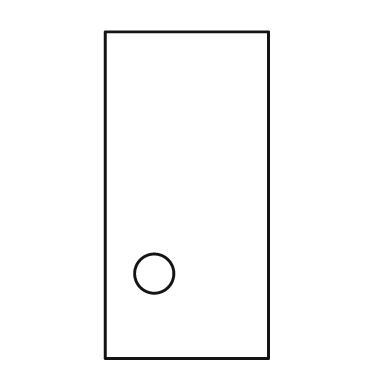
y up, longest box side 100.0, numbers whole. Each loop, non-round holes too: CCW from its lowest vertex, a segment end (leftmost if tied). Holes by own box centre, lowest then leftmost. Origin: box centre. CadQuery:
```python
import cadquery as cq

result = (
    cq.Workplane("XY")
    .moveTo(-25.0, -50.0)
    .lineTo(25.0, -50.0)
    .lineTo(25.0, 50.0)
    .lineTo(-25.0, 50.0)
    .close()
    .moveTo(-10.0, -24.0)
    .circle(6.0)
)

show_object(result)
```